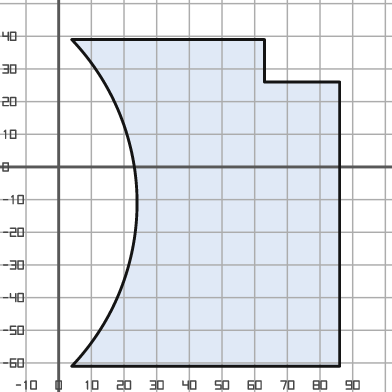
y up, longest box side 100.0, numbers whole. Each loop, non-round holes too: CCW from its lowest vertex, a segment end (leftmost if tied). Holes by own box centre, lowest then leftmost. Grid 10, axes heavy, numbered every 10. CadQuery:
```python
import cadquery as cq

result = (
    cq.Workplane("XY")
    .moveTo(4.0, -61.0)
    .lineTo(86.0, -61.0)
    .lineTo(86.0, 26.0)
    .lineTo(63.0, 26.0)
    .lineTo(63.0, 39.0)
    .lineTo(4.0, 39.0)
    .threePointArc((24.0, -11.0), (4.0, -61.0))
    .close()
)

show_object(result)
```